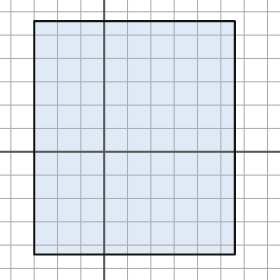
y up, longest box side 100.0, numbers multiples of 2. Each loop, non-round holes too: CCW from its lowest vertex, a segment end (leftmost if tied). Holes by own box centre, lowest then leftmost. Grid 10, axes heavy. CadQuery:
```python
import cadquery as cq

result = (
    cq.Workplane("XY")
    .moveTo(-30.0, -44.0)
    .lineTo(56.0, -44.0)
    .lineTo(56.0, 56.0)
    .lineTo(-30.0, 56.0)
    .close()
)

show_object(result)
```